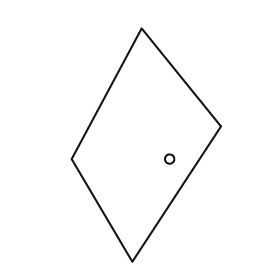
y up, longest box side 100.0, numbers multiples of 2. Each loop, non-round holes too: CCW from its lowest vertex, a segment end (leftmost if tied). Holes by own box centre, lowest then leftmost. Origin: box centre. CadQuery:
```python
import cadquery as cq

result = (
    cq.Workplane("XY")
    .moveTo(-6.0, -50.0)
    .lineTo(32.0, 8.0)
    .lineTo(-2.0, 50.0)
    .lineTo(-32.0, -6.0)
    .close()
    .moveTo(10.0, -6.0)
    .circle(2.0)
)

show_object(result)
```